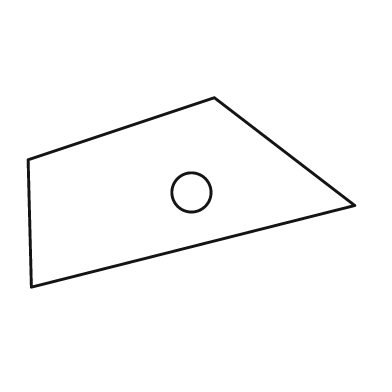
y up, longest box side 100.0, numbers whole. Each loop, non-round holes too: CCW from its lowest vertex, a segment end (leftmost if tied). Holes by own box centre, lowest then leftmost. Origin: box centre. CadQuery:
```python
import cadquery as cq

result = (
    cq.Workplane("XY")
    .moveTo(-49.0, -29.0)
    .lineTo(50.0, -4.0)
    .lineTo(7.0, 29.0)
    .lineTo(-50.0, 10.0)
    .close()
    .moveTo(0.0, 0.0)
    .circle(6.0)
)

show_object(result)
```